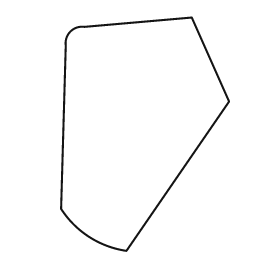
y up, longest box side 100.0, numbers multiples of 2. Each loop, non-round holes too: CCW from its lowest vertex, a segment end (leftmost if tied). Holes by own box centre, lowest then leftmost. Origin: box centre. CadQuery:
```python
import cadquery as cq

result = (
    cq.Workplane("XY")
    .moveTo(-8.0, -50.0)
    .lineTo(36.0, 14.0)
    .lineTo(20.0, 50.0)
    .lineTo(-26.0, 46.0)
    .threePointArc((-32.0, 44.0), (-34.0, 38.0))
    .lineTo(-36.0, -32.0)
    .threePointArc((-24.0, -44.0), (-8.0, -50.0))
    .close()
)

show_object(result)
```